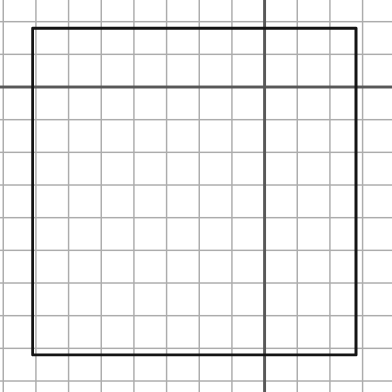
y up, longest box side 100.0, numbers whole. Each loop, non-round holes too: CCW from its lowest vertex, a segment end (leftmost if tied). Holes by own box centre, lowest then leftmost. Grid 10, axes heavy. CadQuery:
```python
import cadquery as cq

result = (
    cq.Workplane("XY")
    .moveTo(-71.0, -82.0)
    .lineTo(28.0, -82.0)
    .lineTo(28.0, 18.0)
    .lineTo(-71.0, 18.0)
    .close()
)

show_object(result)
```